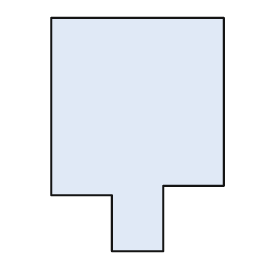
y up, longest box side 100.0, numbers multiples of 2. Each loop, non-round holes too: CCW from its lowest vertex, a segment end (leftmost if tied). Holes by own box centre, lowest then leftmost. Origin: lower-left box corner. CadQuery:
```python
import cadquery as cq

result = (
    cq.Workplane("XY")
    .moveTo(26.0, 0.0)
    .lineTo(48.0, 0.0)
    .lineTo(48.0, 28.0)
    .lineTo(74.0, 28.0)
    .lineTo(74.0, 100.0)
    .lineTo(0.0, 100.0)
    .lineTo(0.0, 24.0)
    .lineTo(26.0, 24.0)
    .close()
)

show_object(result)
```